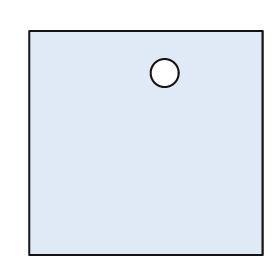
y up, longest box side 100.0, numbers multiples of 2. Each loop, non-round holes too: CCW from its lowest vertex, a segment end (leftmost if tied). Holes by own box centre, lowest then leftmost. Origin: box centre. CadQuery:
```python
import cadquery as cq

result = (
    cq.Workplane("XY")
    .moveTo(-50.0, -48.0)
    .lineTo(50.0, -48.0)
    .lineTo(50.0, 48.0)
    .lineTo(-50.0, 48.0)
    .close()
    .moveTo(8.0, 30.0)
    .circle(6.0)
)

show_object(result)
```